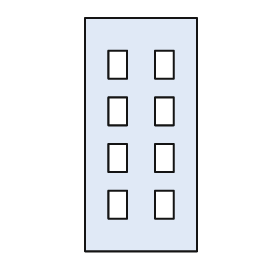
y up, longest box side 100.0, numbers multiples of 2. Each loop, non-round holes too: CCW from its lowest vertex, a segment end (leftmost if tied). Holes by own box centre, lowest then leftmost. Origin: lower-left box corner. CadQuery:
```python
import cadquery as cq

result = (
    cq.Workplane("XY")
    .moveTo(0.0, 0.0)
    .lineTo(48.0, 0.0)
    .lineTo(48.0, 100.0)
    .lineTo(0.0, 100.0)
    .close()
    .moveTo(10.0, 14.0)
    .lineTo(18.0, 14.0)
    .lineTo(18.0, 26.0)
    .lineTo(10.0, 26.0)
    .close()
    .moveTo(30.0, 14.0)
    .lineTo(38.0, 14.0)
    .lineTo(38.0, 26.0)
    .lineTo(30.0, 26.0)
    .close()
    .moveTo(10.0, 34.0)
    .lineTo(18.0, 34.0)
    .lineTo(18.0, 46.0)
    .lineTo(10.0, 46.0)
    .close()
    .moveTo(30.0, 34.0)
    .lineTo(38.0, 34.0)
    .lineTo(38.0, 46.0)
    .lineTo(30.0, 46.0)
    .close()
    .moveTo(10.0, 54.0)
    .lineTo(18.0, 54.0)
    .lineTo(18.0, 66.0)
    .lineTo(10.0, 66.0)
    .close()
    .moveTo(30.0, 54.0)
    .lineTo(38.0, 54.0)
    .lineTo(38.0, 66.0)
    .lineTo(30.0, 66.0)
    .close()
    .moveTo(10.0, 74.0)
    .lineTo(18.0, 74.0)
    .lineTo(18.0, 86.0)
    .lineTo(10.0, 86.0)
    .close()
    .moveTo(30.0, 74.0)
    .lineTo(38.0, 74.0)
    .lineTo(38.0, 86.0)
    .lineTo(30.0, 86.0)
    .close()
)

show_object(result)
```